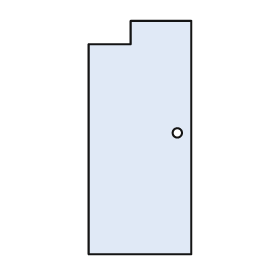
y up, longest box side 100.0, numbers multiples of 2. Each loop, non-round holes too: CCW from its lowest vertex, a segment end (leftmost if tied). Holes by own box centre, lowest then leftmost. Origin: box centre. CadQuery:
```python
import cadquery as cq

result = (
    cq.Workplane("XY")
    .moveTo(-22.0, -50.0)
    .lineTo(22.0, -50.0)
    .lineTo(22.0, 50.0)
    .lineTo(-4.0, 50.0)
    .lineTo(-4.0, 40.0)
    .lineTo(-22.0, 40.0)
    .close()
    .moveTo(16.0, 2.0)
    .circle(2.0)
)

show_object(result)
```